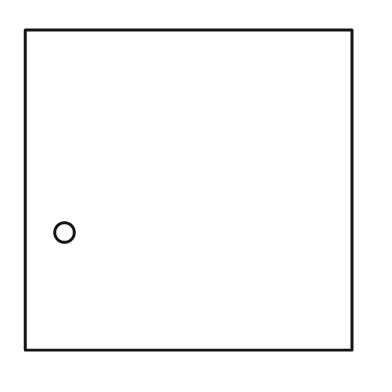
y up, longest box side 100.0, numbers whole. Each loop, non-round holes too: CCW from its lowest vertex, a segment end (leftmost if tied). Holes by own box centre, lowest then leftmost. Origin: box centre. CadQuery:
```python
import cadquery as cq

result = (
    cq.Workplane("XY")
    .moveTo(-50.0, -49.0)
    .lineTo(50.0, -49.0)
    .lineTo(50.0, 49.0)
    .lineTo(-50.0, 49.0)
    .close()
    .moveTo(-38.0, -13.0)
    .circle(3.0)
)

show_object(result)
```